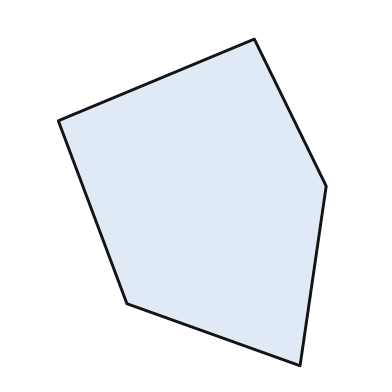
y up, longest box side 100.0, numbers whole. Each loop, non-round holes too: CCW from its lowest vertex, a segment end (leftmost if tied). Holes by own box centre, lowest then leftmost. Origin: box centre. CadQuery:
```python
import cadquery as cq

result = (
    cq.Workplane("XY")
    .moveTo(33.0, -50.0)
    .lineTo(41.0, 5.0)
    .lineTo(19.0, 50.0)
    .lineTo(-41.0, 25.0)
    .lineTo(-20.0, -31.0)
    .close()
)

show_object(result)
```